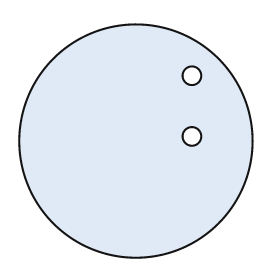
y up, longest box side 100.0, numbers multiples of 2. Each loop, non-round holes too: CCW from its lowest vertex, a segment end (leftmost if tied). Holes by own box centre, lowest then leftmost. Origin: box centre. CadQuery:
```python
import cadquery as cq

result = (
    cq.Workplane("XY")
    .moveTo(0.0, 0.0)
    .circle(50.0)
    .moveTo(24.0, 2.0)
    .circle(4.0)
    .moveTo(24.0, 28.0)
    .circle(4.0)
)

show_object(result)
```